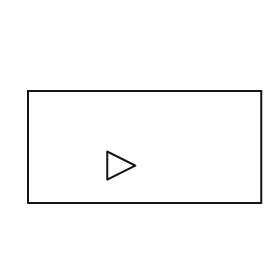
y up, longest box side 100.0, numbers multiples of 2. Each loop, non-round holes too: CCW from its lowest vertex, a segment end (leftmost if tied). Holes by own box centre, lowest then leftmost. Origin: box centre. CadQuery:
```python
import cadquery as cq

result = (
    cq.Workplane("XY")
    .moveTo(-50.0, -24.0)
    .lineTo(50.0, -24.0)
    .lineTo(50.0, 24.0)
    .lineTo(-50.0, 24.0)
    .close()
    .moveTo(-16.0, -14.0)
    .lineTo(-4.0, -8.0)
    .lineTo(-16.0, -2.0)
    .close()
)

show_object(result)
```